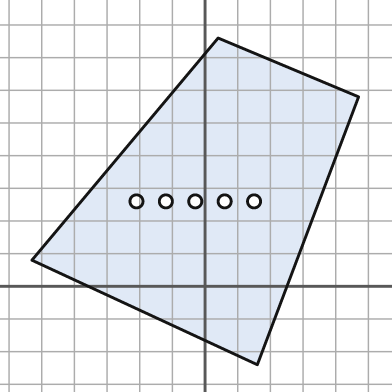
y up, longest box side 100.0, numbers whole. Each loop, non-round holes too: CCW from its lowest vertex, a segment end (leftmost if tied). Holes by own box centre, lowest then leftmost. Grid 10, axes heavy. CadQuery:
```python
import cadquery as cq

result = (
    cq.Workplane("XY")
    .moveTo(16.0, -24.0)
    .lineTo(47.0, 58.0)
    .lineTo(4.0, 76.0)
    .lineTo(-53.0, 8.0)
    .close()
    .moveTo(-21.0, 26.0)
    .circle(2.0)
    .moveTo(-12.0, 26.0)
    .circle(2.0)
    .moveTo(-3.0, 26.0)
    .circle(2.0)
    .moveTo(6.0, 26.0)
    .circle(2.0)
    .moveTo(15.0, 26.0)
    .circle(2.0)
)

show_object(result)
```